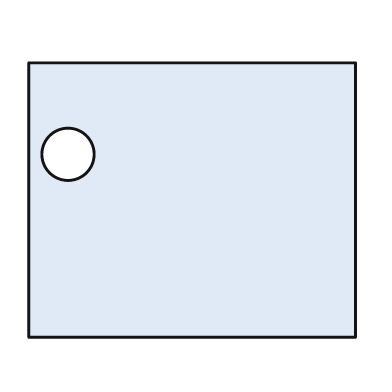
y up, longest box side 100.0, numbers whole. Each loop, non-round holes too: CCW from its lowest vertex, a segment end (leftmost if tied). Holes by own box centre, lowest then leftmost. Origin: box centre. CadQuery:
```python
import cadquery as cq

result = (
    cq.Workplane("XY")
    .moveTo(-50.0, -42.0)
    .lineTo(50.0, -42.0)
    .lineTo(50.0, 42.0)
    .lineTo(-50.0, 42.0)
    .close()
    .moveTo(-38.0, 14.0)
    .circle(8.0)
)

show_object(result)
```